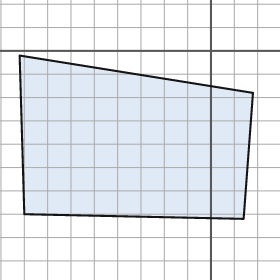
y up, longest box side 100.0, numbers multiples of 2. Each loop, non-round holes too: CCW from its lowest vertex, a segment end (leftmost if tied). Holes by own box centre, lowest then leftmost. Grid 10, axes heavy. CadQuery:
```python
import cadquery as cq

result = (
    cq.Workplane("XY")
    .moveTo(14.0, -72.0)
    .lineTo(18.0, -18.0)
    .lineTo(-82.0, -2.0)
    .lineTo(-80.0, -70.0)
    .close()
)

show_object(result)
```